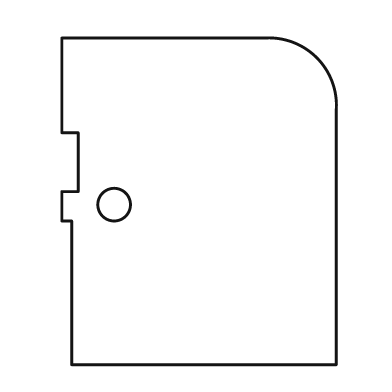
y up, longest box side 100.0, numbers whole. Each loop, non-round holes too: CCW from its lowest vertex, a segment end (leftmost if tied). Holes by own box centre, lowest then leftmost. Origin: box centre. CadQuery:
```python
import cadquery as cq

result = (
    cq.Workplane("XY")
    .moveTo(-39.0, -50.0)
    .lineTo(42.0, -50.0)
    .lineTo(42.0, 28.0)
    .threePointArc((36.0, 44.0), (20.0, 50.0))
    .lineTo(-42.0, 50.0)
    .lineTo(-42.0, 21.0)
    .lineTo(-37.0, 21.0)
    .lineTo(-37.0, 3.0)
    .lineTo(-42.0, 3.0)
    .lineTo(-42.0, -6.0)
    .lineTo(-39.0, -6.0)
    .close()
    .moveTo(-26.0, -1.0)
    .circle(5.0)
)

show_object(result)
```